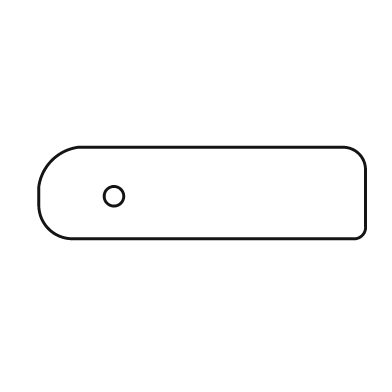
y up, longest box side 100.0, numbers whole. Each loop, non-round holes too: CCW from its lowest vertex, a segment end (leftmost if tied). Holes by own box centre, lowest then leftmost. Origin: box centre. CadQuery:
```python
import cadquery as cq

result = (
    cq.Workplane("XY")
    .moveTo(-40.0, -14.0)
    .lineTo(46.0, -14.0)
    .threePointArc((49.0, -13.0), (50.0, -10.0))
    .lineTo(50.0, 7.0)
    .threePointArc((48.0, 12.0), (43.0, 14.0))
    .lineTo(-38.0, 14.0)
    .threePointArc((-46.0, 10.0), (-50.0, 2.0))
    .lineTo(-50.0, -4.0)
    .threePointArc((-47.0, -11.0), (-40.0, -14.0))
    .close()
    .moveTo(-27.0, -1.0)
    .circle(3.0)
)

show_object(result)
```